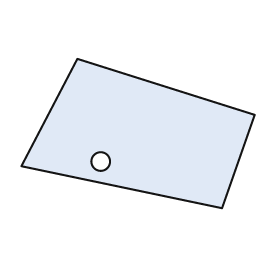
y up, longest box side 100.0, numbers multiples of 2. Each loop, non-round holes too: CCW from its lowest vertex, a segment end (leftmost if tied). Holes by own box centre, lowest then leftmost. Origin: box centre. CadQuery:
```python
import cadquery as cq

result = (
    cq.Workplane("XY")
    .moveTo(36.0, -32.0)
    .lineTo(50.0, 8.0)
    .lineTo(-26.0, 32.0)
    .lineTo(-50.0, -14.0)
    .close()
    .moveTo(-16.0, -12.0)
    .circle(4.0)
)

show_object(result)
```